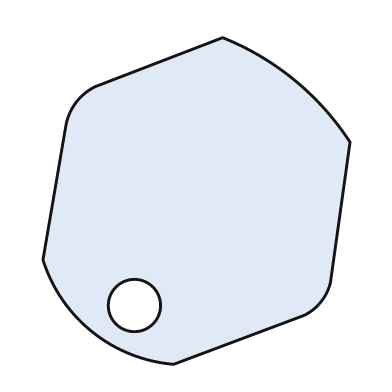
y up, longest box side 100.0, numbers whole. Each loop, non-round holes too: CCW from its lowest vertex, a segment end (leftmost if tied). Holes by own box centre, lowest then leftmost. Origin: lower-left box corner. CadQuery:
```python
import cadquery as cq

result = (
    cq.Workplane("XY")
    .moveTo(40.0, 0.0)
    .lineTo(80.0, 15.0)
    .threePointArc((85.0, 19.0), (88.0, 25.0))
    .lineTo(94.0, 68.0)
    .threePointArc((77.0, 87.0), (55.0, 100.0))
    .lineTo(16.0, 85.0)
    .threePointArc((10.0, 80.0), (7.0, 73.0))
    .lineTo(0.0, 32.0)
    .threePointArc((15.0, 10.0), (40.0, 0.0))
    .close()
    .moveTo(28.0, 18.0)
    .circle(8.0)
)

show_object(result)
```